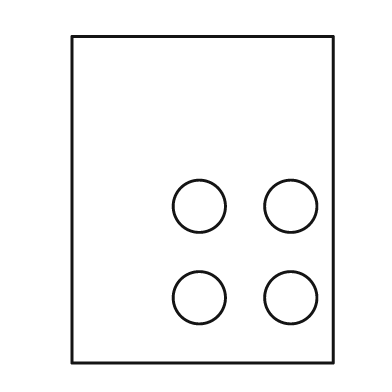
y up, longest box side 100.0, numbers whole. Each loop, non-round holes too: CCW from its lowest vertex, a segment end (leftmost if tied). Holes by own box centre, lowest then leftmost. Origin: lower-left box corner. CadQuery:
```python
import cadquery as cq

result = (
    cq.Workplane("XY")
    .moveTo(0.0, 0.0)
    .lineTo(80.0, 0.0)
    .lineTo(80.0, 100.0)
    .lineTo(0.0, 100.0)
    .close()
    .moveTo(39.0, 20.0)
    .circle(8.0)
    .moveTo(67.0, 20.0)
    .circle(8.0)
    .moveTo(39.0, 48.0)
    .circle(8.0)
    .moveTo(67.0, 48.0)
    .circle(8.0)
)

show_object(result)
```